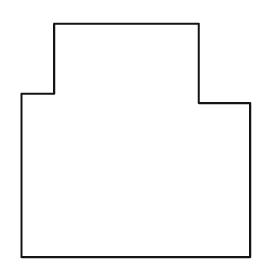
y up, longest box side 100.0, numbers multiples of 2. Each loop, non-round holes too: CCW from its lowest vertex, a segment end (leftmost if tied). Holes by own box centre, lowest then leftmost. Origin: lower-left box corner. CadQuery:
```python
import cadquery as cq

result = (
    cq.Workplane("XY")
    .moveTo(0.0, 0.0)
    .lineTo(98.0, 0.0)
    .lineTo(98.0, 66.0)
    .lineTo(76.0, 66.0)
    .lineTo(76.0, 100.0)
    .lineTo(14.0, 100.0)
    .lineTo(14.0, 70.0)
    .lineTo(0.0, 70.0)
    .close()
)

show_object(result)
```